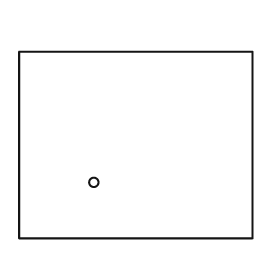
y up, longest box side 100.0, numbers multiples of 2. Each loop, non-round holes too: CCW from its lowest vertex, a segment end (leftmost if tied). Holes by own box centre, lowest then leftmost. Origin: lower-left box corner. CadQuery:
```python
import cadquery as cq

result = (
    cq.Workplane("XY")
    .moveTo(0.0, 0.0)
    .lineTo(100.0, 0.0)
    .lineTo(100.0, 80.0)
    .lineTo(0.0, 80.0)
    .close()
    .moveTo(32.0, 24.0)
    .circle(2.0)
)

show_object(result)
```